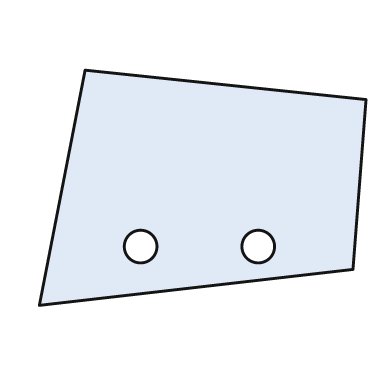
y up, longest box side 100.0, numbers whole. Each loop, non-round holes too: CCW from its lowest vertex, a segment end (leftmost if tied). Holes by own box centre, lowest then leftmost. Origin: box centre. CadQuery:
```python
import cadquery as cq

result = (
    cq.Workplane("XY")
    .moveTo(-50.0, -36.0)
    .lineTo(46.0, -25.0)
    .lineTo(50.0, 27.0)
    .lineTo(-36.0, 36.0)
    .close()
    .moveTo(-19.0, -18.0)
    .circle(5.0)
    .moveTo(17.0, -18.0)
    .circle(5.0)
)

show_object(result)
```